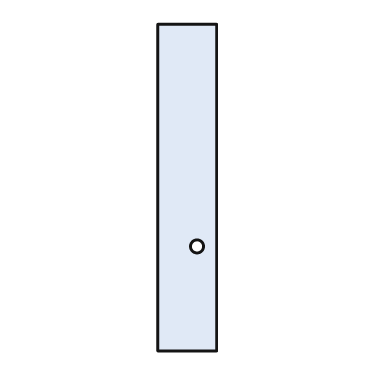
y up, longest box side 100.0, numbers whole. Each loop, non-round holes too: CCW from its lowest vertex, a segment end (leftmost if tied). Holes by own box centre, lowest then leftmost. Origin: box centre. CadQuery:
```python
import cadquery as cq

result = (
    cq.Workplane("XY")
    .moveTo(-9.0, -50.0)
    .lineTo(9.0, -50.0)
    .lineTo(9.0, 50.0)
    .lineTo(-9.0, 50.0)
    .close()
    .moveTo(3.0, -18.0)
    .circle(2.0)
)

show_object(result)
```